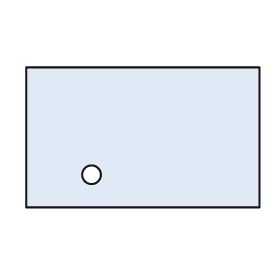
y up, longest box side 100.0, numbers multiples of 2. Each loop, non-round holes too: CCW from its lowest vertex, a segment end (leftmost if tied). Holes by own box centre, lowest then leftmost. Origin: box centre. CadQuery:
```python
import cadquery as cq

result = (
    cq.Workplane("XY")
    .moveTo(-50.0, -30.0)
    .lineTo(50.0, -30.0)
    .lineTo(50.0, 30.0)
    .lineTo(-50.0, 30.0)
    .close()
    .moveTo(-22.0, -16.0)
    .circle(4.0)
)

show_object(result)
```